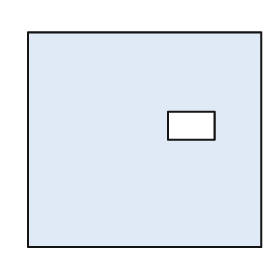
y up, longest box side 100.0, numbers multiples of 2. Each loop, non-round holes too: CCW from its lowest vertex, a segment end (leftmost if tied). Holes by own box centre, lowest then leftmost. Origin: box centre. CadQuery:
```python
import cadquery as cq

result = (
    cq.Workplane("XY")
    .moveTo(-50.0, -46.0)
    .lineTo(50.0, -46.0)
    .lineTo(50.0, 46.0)
    .lineTo(-50.0, 46.0)
    .close()
    .moveTo(10.0, 0.0)
    .lineTo(30.0, 0.0)
    .lineTo(30.0, 12.0)
    .lineTo(10.0, 12.0)
    .close()
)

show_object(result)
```